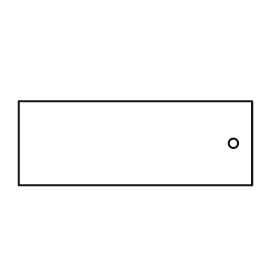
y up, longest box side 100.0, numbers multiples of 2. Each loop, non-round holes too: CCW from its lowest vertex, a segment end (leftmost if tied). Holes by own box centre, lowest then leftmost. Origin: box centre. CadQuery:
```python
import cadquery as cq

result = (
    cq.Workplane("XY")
    .moveTo(-50.0, -18.0)
    .lineTo(50.0, -18.0)
    .lineTo(50.0, 18.0)
    .lineTo(-50.0, 18.0)
    .close()
    .moveTo(42.0, 0.0)
    .circle(2.0)
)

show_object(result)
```